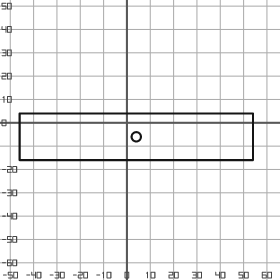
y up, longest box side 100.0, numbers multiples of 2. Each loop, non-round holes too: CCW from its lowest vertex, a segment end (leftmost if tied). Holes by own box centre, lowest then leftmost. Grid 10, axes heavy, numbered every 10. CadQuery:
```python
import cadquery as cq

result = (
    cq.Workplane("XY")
    .moveTo(-46.0, -16.0)
    .lineTo(54.0, -16.0)
    .lineTo(54.0, 4.0)
    .lineTo(-46.0, 4.0)
    .close()
    .moveTo(4.0, -6.0)
    .circle(2.0)
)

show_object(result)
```